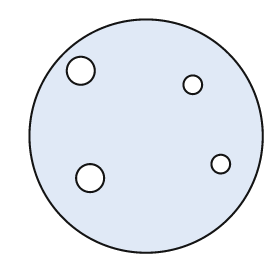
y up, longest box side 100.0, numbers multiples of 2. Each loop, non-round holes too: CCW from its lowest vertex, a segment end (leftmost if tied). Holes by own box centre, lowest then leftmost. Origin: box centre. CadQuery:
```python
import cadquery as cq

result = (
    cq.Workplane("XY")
    .moveTo(0.0, 0.0)
    .circle(50.0)
    .moveTo(-24.0, -18.0)
    .circle(6.0)
    .moveTo(32.0, -12.0)
    .circle(4.0)
    .moveTo(20.0, 22.0)
    .circle(4.0)
    .moveTo(-28.0, 28.0)
    .circle(6.0)
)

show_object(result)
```